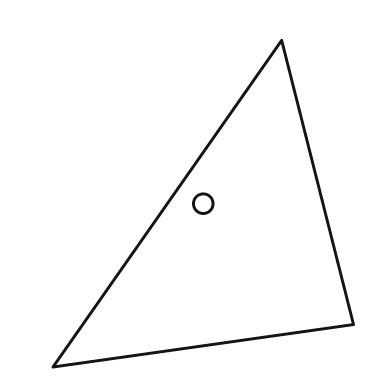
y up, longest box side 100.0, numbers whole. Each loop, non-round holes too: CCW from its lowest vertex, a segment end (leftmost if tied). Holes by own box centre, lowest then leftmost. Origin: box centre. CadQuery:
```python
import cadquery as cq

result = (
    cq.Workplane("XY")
    .moveTo(-46.0, -50.0)
    .lineTo(46.0, -37.0)
    .lineTo(24.0, 50.0)
    .close()
    .moveTo(0.0, 0.0)
    .circle(3.0)
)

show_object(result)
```